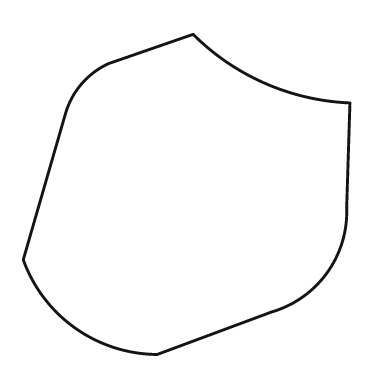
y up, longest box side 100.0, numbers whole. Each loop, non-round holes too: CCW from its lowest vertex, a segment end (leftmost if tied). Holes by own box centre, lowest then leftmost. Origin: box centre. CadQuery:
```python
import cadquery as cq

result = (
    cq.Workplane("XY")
    .moveTo(-9.0, -49.0)
    .lineTo(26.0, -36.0)
    .threePointArc((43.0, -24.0), (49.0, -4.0))
    .lineTo(50.0, 28.0)
    .threePointArc((24.0, 34.0), (2.0, 49.0))
    .lineTo(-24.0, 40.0)
    .threePointArc((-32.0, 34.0), (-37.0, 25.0))
    .lineTo(-50.0, -20.0)
    .threePointArc((-34.0, -41.0), (-9.0, -49.0))
    .close()
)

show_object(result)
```